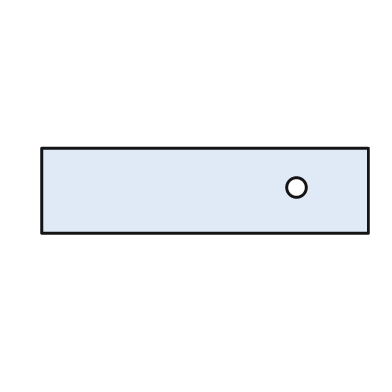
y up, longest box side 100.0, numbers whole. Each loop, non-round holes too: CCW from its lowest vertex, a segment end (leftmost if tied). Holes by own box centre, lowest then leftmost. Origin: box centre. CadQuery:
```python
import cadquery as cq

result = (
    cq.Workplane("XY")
    .moveTo(-50.0, -13.0)
    .lineTo(50.0, -13.0)
    .lineTo(50.0, 13.0)
    .lineTo(-50.0, 13.0)
    .close()
    .moveTo(28.0, 1.0)
    .circle(3.0)
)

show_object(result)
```